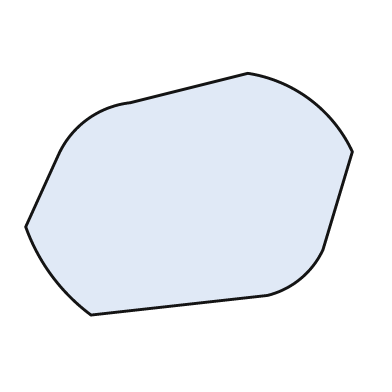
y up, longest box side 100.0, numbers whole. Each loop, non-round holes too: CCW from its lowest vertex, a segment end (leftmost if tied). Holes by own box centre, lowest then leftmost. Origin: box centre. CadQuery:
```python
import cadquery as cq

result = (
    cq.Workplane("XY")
    .moveTo(-30.0, -37.0)
    .lineTo(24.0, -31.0)
    .threePointArc((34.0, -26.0), (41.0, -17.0))
    .lineTo(50.0, 13.0)
    .threePointArc((37.0, 29.0), (18.0, 37.0))
    .lineTo(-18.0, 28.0)
    .threePointArc((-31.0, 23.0), (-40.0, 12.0))
    .lineTo(-50.0, -10.0)
    .threePointArc((-42.0, -25.0), (-30.0, -37.0))
    .close()
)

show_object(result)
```